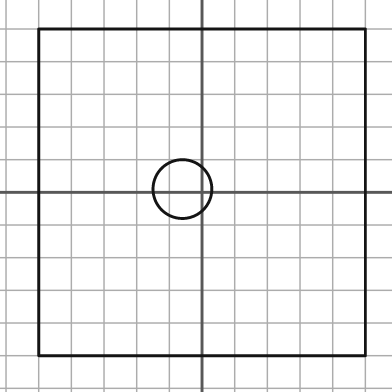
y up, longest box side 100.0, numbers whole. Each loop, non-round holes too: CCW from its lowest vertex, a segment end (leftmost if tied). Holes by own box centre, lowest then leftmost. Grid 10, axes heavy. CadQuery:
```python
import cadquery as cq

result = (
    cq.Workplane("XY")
    .moveTo(-50.0, -50.0)
    .lineTo(50.0, -50.0)
    .lineTo(50.0, 50.0)
    .lineTo(-50.0, 50.0)
    .close()
    .moveTo(-6.0, 1.0)
    .circle(9.0)
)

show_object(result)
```